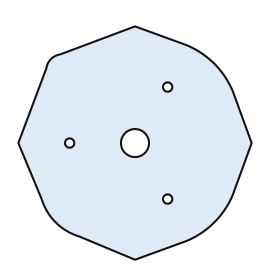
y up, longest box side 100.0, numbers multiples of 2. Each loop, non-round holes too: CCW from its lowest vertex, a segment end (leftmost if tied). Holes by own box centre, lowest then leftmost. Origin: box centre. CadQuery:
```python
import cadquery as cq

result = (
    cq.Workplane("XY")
    .moveTo(0.0, -50.0)
    .lineTo(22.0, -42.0)
    .threePointArc((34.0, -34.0), (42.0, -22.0))
    .lineTo(50.0, 0.0)
    .lineTo(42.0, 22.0)
    .threePointArc((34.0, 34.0), (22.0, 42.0))
    .lineTo(0.0, 50.0)
    .lineTo(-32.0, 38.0)
    .threePointArc((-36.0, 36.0), (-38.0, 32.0))
    .lineTo(-50.0, 0.0)
    .lineTo(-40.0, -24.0)
    .threePointArc((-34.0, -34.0), (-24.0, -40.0))
    .close()
    .moveTo(14.0, -24.0)
    .circle(2.0)
    .moveTo(-28.0, 0.0)
    .circle(2.0)
    .moveTo(0.0, 0.0)
    .circle(6.0)
    .moveTo(14.0, 24.0)
    .circle(2.0)
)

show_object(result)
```